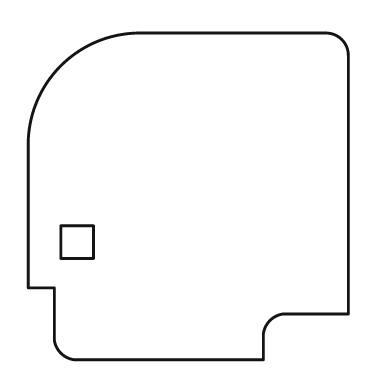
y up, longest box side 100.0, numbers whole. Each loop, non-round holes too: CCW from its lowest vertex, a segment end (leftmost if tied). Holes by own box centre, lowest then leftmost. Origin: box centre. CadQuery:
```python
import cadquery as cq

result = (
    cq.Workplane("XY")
    .moveTo(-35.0, -50.0)
    .lineTo(23.0, -50.0)
    .lineTo(23.0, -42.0)
    .threePointArc((25.0, -38.0), (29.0, -36.0))
    .lineTo(49.0, -36.0)
    .lineTo(49.0, 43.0)
    .threePointArc((47.0, 48.0), (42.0, 50.0))
    .lineTo(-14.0, 50.0)
    .threePointArc((-39.0, 40.0), (-49.0, 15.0))
    .lineTo(-49.0, -28.0)
    .lineTo(-41.0, -28.0)
    .lineTo(-41.0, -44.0)
    .threePointArc((-39.0, -48.0), (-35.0, -50.0))
    .close()
    .moveTo(-39.0, -19.0)
    .lineTo(-29.0, -19.0)
    .lineTo(-29.0, -9.0)
    .lineTo(-39.0, -9.0)
    .close()
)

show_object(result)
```